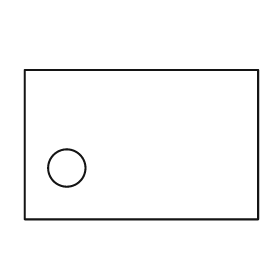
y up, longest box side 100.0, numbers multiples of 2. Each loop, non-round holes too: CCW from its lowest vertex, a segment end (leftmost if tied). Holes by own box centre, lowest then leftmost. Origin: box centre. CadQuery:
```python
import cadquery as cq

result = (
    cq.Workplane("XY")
    .moveTo(-50.0, -32.0)
    .lineTo(50.0, -32.0)
    .lineTo(50.0, 32.0)
    .lineTo(-50.0, 32.0)
    .close()
    .moveTo(-32.0, -10.0)
    .circle(8.0)
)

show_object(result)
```